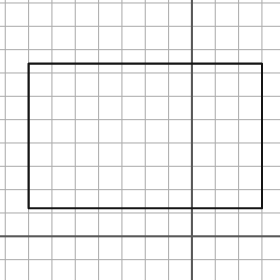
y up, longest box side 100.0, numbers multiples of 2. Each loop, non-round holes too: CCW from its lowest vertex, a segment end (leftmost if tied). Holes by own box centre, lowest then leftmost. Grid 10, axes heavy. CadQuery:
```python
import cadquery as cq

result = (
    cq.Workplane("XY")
    .moveTo(-70.0, 12.0)
    .lineTo(30.0, 12.0)
    .lineTo(30.0, 74.0)
    .lineTo(-70.0, 74.0)
    .close()
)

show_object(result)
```